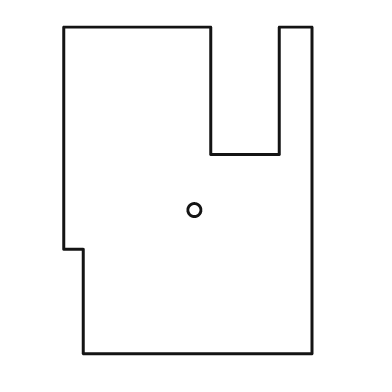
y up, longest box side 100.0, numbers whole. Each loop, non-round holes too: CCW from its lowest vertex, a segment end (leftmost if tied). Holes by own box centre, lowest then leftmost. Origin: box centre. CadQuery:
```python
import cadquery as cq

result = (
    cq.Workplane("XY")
    .moveTo(-32.0, -50.0)
    .lineTo(38.0, -50.0)
    .lineTo(38.0, 50.0)
    .lineTo(28.0, 50.0)
    .lineTo(28.0, 11.0)
    .lineTo(7.0, 11.0)
    .lineTo(7.0, 50.0)
    .lineTo(-38.0, 50.0)
    .lineTo(-38.0, -18.0)
    .lineTo(-32.0, -18.0)
    .close()
    .moveTo(2.0, -6.0)
    .circle(2.0)
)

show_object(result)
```